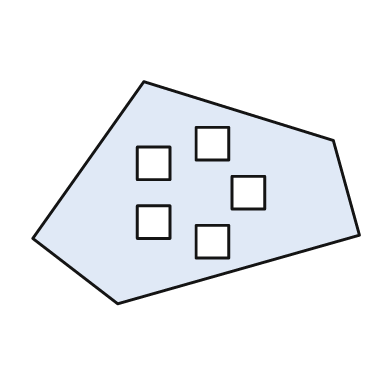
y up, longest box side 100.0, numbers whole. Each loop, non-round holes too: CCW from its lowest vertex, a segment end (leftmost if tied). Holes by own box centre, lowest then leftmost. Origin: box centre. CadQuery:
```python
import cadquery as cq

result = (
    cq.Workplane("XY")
    .moveTo(-24.0, -34.0)
    .lineTo(50.0, -13.0)
    .lineTo(42.0, 16.0)
    .lineTo(-16.0, 34.0)
    .lineTo(-50.0, -14.0)
    .close()
    .moveTo(0.0, -20.0)
    .lineTo(10.0, -20.0)
    .lineTo(10.0, -10.0)
    .lineTo(0.0, -10.0)
    .close()
    .moveTo(-18.0, -14.0)
    .lineTo(-8.0, -14.0)
    .lineTo(-8.0, -4.0)
    .lineTo(-18.0, -4.0)
    .close()
    .moveTo(11.0, -5.0)
    .lineTo(21.0, -5.0)
    .lineTo(21.0, 5.0)
    .lineTo(11.0, 5.0)
    .close()
    .moveTo(-18.0, 4.0)
    .lineTo(-8.0, 4.0)
    .lineTo(-8.0, 14.0)
    .lineTo(-18.0, 14.0)
    .close()
    .moveTo(0.0, 10.0)
    .lineTo(10.0, 10.0)
    .lineTo(10.0, 20.0)
    .lineTo(0.0, 20.0)
    .close()
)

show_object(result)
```